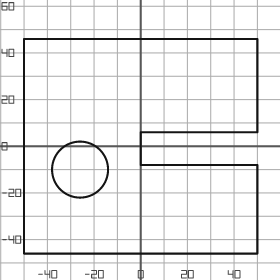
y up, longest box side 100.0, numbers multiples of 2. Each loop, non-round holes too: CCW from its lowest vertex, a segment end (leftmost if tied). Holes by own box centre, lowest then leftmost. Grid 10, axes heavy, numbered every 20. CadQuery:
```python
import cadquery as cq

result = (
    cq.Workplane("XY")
    .moveTo(-50.0, -46.0)
    .lineTo(50.0, -46.0)
    .lineTo(50.0, -8.0)
    .lineTo(0.0, -8.0)
    .lineTo(0.0, 6.0)
    .lineTo(50.0, 6.0)
    .lineTo(50.0, 46.0)
    .lineTo(-50.0, 46.0)
    .close()
    .moveTo(-26.0, -10.0)
    .circle(12.0)
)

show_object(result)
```